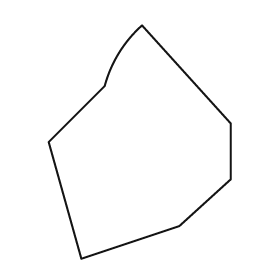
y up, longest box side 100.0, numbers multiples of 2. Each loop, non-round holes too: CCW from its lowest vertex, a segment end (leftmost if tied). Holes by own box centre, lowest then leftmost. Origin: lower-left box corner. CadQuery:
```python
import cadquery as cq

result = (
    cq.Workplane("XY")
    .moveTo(14.0, 0.0)
    .lineTo(56.0, 14.0)
    .lineTo(78.0, 34.0)
    .lineTo(78.0, 58.0)
    .lineTo(40.0, 100.0)
    .threePointArc((30.0, 88.0), (24.0, 74.0))
    .lineTo(0.0, 50.0)
    .close()
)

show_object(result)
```